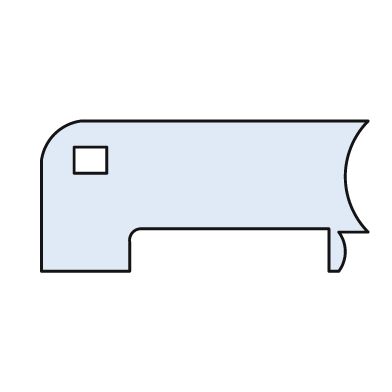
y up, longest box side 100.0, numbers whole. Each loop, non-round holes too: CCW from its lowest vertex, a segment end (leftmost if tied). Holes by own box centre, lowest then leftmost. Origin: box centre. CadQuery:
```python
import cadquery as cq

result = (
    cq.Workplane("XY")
    .moveTo(-50.0, -23.0)
    .lineTo(-23.0, -23.0)
    .lineTo(-23.0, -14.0)
    .threePointArc((-22.0, -11.0), (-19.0, -10.0))
    .lineTo(38.0, -10.0)
    .lineTo(38.0, -23.0)
    .lineTo(41.0, -23.0)
    .threePointArc((43.0, -17.0), (41.0, -11.0))
    .lineTo(50.0, -11.0)
    .threePointArc((43.0, 6.0), (50.0, 23.0))
    .lineTo(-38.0, 23.0)
    .threePointArc((-46.0, 19.0), (-50.0, 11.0))
    .close()
    .moveTo(-40.0, 7.0)
    .lineTo(-30.0, 7.0)
    .lineTo(-30.0, 15.0)
    .lineTo(-40.0, 15.0)
    .close()
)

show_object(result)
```